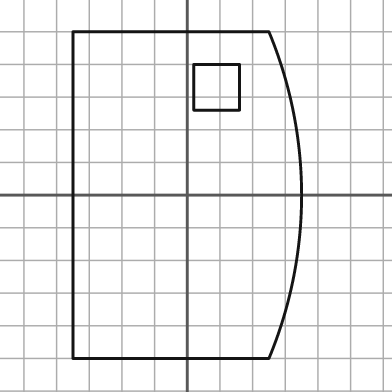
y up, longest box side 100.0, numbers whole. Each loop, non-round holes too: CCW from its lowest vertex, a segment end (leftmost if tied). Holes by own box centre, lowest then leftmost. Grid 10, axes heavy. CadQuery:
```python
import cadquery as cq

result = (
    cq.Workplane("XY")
    .moveTo(-35.0, -50.0)
    .lineTo(25.0, -50.0)
    .threePointArc((35.0, 0.0), (25.0, 50.0))
    .lineTo(-35.0, 50.0)
    .close()
    .moveTo(2.0, 26.0)
    .lineTo(16.0, 26.0)
    .lineTo(16.0, 40.0)
    .lineTo(2.0, 40.0)
    .close()
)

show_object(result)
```